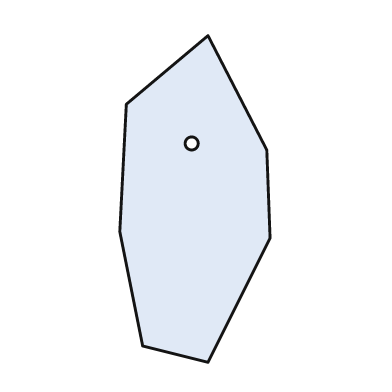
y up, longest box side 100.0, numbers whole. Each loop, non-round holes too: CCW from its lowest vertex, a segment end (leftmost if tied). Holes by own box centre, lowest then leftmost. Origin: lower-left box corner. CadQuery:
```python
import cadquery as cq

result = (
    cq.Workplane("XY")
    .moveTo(27.0, 0.0)
    .lineTo(46.0, 38.0)
    .lineTo(45.0, 65.0)
    .lineTo(27.0, 100.0)
    .lineTo(2.0, 79.0)
    .lineTo(0.0, 40.0)
    .lineTo(7.0, 5.0)
    .close()
    .moveTo(22.0, 67.0)
    .circle(2.0)
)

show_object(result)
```